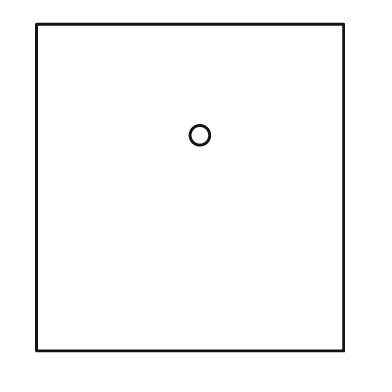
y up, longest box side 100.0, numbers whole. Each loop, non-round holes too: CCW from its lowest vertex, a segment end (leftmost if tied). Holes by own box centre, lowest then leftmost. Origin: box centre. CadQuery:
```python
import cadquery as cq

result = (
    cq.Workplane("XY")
    .moveTo(-47.0, -50.0)
    .lineTo(47.0, -50.0)
    .lineTo(47.0, 50.0)
    .lineTo(-47.0, 50.0)
    .close()
    .moveTo(3.0, 16.0)
    .circle(3.0)
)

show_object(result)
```